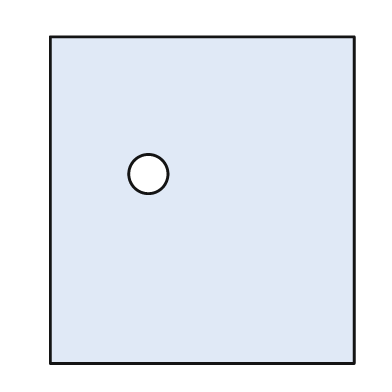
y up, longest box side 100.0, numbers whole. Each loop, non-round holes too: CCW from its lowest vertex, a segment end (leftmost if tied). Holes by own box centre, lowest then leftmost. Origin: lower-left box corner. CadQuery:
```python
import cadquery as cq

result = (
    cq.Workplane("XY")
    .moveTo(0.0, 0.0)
    .lineTo(93.0, 0.0)
    .lineTo(93.0, 100.0)
    .lineTo(0.0, 100.0)
    .close()
    .moveTo(30.0, 58.0)
    .circle(6.0)
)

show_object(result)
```